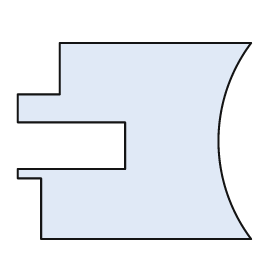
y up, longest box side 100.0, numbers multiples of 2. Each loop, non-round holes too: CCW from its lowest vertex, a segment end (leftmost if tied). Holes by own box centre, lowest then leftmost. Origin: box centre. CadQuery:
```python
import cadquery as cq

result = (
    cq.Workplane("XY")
    .moveTo(-40.0, -42.0)
    .lineTo(50.0, -42.0)
    .threePointArc((36.0, 0.0), (50.0, 42.0))
    .lineTo(-32.0, 42.0)
    .lineTo(-32.0, 20.0)
    .lineTo(-50.0, 20.0)
    .lineTo(-50.0, 8.0)
    .lineTo(-4.0, 8.0)
    .lineTo(-4.0, -12.0)
    .lineTo(-50.0, -12.0)
    .lineTo(-50.0, -16.0)
    .lineTo(-40.0, -16.0)
    .close()
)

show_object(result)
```